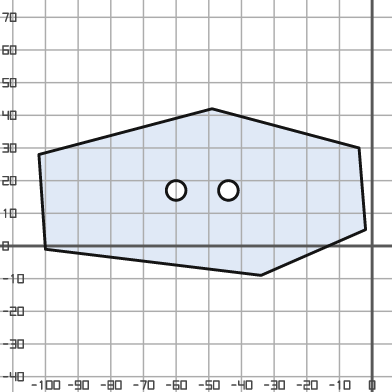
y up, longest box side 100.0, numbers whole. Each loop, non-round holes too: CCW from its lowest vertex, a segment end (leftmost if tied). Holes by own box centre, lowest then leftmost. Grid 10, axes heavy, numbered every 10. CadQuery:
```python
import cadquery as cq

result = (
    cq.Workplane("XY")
    .moveTo(-34.0, -9.0)
    .lineTo(-2.0, 5.0)
    .lineTo(-4.0, 30.0)
    .lineTo(-49.0, 42.0)
    .lineTo(-102.0, 28.0)
    .lineTo(-100.0, -1.0)
    .close()
    .moveTo(-60.0, 17.0)
    .circle(3.0)
    .moveTo(-44.0, 17.0)
    .circle(3.0)
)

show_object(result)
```